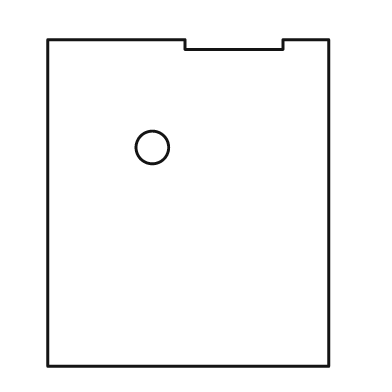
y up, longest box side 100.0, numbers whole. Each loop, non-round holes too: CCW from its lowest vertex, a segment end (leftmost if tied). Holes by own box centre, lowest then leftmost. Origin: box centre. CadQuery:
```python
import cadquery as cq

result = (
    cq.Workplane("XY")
    .moveTo(-43.0, -50.0)
    .lineTo(43.0, -50.0)
    .lineTo(43.0, 50.0)
    .lineTo(29.0, 50.0)
    .lineTo(29.0, 47.0)
    .lineTo(-1.0, 47.0)
    .lineTo(-1.0, 50.0)
    .lineTo(-43.0, 50.0)
    .close()
    .moveTo(-11.0, 17.0)
    .circle(5.0)
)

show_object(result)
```